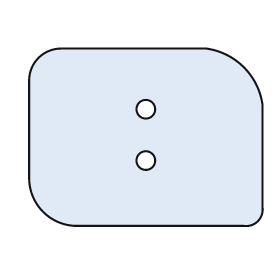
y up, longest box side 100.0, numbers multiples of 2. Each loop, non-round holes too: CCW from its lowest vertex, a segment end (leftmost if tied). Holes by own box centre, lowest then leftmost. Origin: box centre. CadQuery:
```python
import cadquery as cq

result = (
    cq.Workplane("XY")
    .moveTo(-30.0, -38.0)
    .lineTo(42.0, -38.0)
    .threePointArc((48.0, -36.0), (50.0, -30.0))
    .lineTo(50.0, 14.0)
    .threePointArc((42.0, 30.0), (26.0, 38.0))
    .lineTo(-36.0, 38.0)
    .threePointArc((-46.0, 34.0), (-50.0, 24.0))
    .lineTo(-50.0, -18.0)
    .threePointArc((-44.0, -32.0), (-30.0, -38.0))
    .close()
    .moveTo(0.0, -10.0)
    .circle(4.0)
    .moveTo(0.0, 12.0)
    .circle(4.0)
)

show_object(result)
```